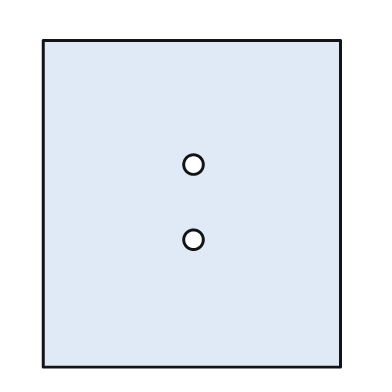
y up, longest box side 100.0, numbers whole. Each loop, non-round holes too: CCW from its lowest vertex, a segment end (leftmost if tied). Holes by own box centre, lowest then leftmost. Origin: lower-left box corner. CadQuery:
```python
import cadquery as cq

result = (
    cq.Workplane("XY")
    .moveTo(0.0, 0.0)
    .lineTo(91.0, 0.0)
    .lineTo(91.0, 100.0)
    .lineTo(0.0, 100.0)
    .close()
    .moveTo(46.0, 39.0)
    .circle(3.0)
    .moveTo(46.0, 62.0)
    .circle(3.0)
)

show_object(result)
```